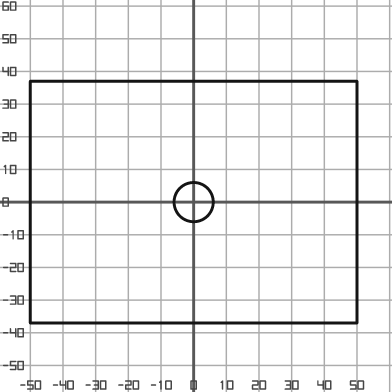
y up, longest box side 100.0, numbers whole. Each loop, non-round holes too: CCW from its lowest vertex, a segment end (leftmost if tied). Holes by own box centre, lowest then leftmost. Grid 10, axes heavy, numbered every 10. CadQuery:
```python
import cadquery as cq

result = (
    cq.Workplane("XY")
    .moveTo(-50.0, -37.0)
    .lineTo(50.0, -37.0)
    .lineTo(50.0, 37.0)
    .lineTo(-50.0, 37.0)
    .close()
    .moveTo(0.0, 0.0)
    .circle(6.0)
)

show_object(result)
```